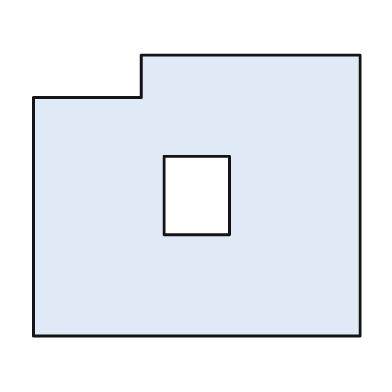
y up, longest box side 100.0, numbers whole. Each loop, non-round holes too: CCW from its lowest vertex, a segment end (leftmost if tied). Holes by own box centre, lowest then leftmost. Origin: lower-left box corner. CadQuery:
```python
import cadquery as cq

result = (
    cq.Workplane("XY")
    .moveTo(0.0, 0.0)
    .lineTo(100.0, 0.0)
    .lineTo(100.0, 86.0)
    .lineTo(33.0, 86.0)
    .lineTo(33.0, 73.0)
    .lineTo(0.0, 73.0)
    .close()
    .moveTo(40.0, 31.0)
    .lineTo(60.0, 31.0)
    .lineTo(60.0, 55.0)
    .lineTo(40.0, 55.0)
    .close()
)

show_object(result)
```